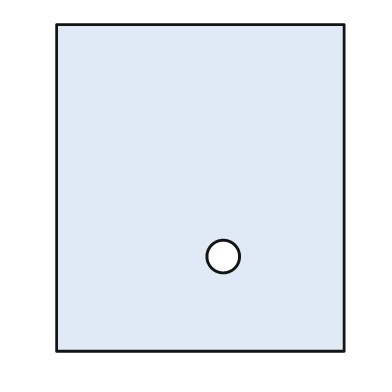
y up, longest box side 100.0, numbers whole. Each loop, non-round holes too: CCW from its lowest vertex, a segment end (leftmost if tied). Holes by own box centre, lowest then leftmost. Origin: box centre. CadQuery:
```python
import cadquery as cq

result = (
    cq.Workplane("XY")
    .moveTo(-44.0, -50.0)
    .lineTo(44.0, -50.0)
    .lineTo(44.0, 50.0)
    .lineTo(-44.0, 50.0)
    .close()
    .moveTo(7.0, -21.0)
    .circle(5.0)
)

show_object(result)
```